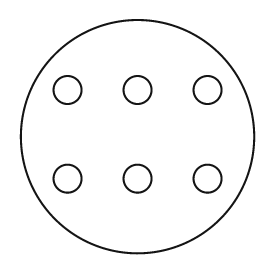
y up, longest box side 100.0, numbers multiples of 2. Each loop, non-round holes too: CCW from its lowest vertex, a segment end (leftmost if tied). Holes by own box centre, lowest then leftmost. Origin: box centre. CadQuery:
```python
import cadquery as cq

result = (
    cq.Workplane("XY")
    .moveTo(0.0, 0.0)
    .circle(50.0)
    .moveTo(-30.0, -18.0)
    .circle(6.0)
    .moveTo(0.0, -18.0)
    .circle(6.0)
    .moveTo(30.0, -18.0)
    .circle(6.0)
    .moveTo(-30.0, 20.0)
    .circle(6.0)
    .moveTo(0.0, 20.0)
    .circle(6.0)
    .moveTo(30.0, 20.0)
    .circle(6.0)
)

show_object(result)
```